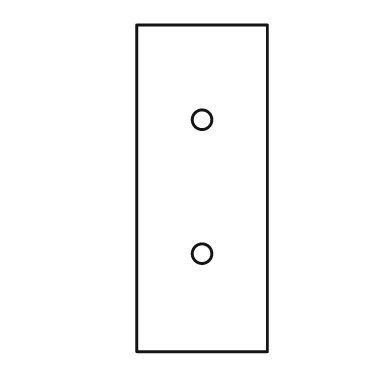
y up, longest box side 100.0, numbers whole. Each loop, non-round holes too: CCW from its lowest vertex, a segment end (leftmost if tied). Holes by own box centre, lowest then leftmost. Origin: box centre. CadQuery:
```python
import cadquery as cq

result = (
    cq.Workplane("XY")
    .moveTo(-20.0, -50.0)
    .lineTo(20.0, -50.0)
    .lineTo(20.0, 50.0)
    .lineTo(-20.0, 50.0)
    .close()
    .moveTo(0.0, -20.0)
    .circle(3.0)
    .moveTo(0.0, 21.0)
    .circle(3.0)
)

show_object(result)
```